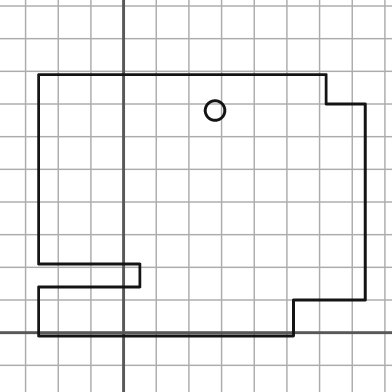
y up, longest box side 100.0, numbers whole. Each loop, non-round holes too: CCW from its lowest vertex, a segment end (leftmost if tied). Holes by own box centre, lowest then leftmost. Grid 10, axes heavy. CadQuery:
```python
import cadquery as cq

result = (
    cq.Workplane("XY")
    .moveTo(-26.0, -1.0)
    .lineTo(52.0, -1.0)
    .lineTo(52.0, 10.0)
    .lineTo(74.0, 10.0)
    .lineTo(74.0, 70.0)
    .lineTo(62.0, 70.0)
    .lineTo(62.0, 79.0)
    .lineTo(-26.0, 79.0)
    .lineTo(-26.0, 21.0)
    .lineTo(5.0, 21.0)
    .lineTo(5.0, 14.0)
    .lineTo(-26.0, 14.0)
    .close()
    .moveTo(28.0, 68.0)
    .circle(3.0)
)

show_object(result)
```